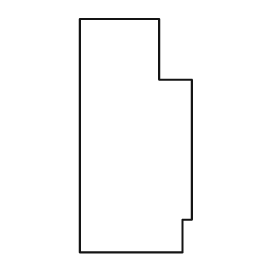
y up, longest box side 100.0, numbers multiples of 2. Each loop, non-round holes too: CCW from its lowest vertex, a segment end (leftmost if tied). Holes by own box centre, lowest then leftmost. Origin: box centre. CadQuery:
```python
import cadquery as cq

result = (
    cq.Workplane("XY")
    .moveTo(-24.0, -50.0)
    .lineTo(20.0, -50.0)
    .lineTo(20.0, -36.0)
    .lineTo(24.0, -36.0)
    .lineTo(24.0, 24.0)
    .lineTo(10.0, 24.0)
    .lineTo(10.0, 50.0)
    .lineTo(-24.0, 50.0)
    .close()
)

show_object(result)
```